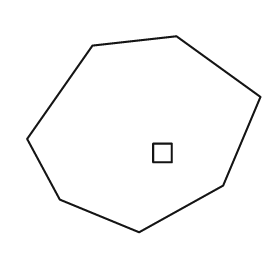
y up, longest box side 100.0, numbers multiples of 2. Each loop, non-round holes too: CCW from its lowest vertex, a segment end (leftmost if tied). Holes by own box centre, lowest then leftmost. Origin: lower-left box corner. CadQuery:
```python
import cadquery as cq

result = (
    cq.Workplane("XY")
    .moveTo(48.0, 0.0)
    .lineTo(84.0, 20.0)
    .lineTo(100.0, 58.0)
    .lineTo(64.0, 84.0)
    .lineTo(28.0, 80.0)
    .lineTo(0.0, 40.0)
    .lineTo(14.0, 14.0)
    .close()
    .moveTo(54.0, 30.0)
    .lineTo(62.0, 30.0)
    .lineTo(62.0, 38.0)
    .lineTo(54.0, 38.0)
    .close()
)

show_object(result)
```